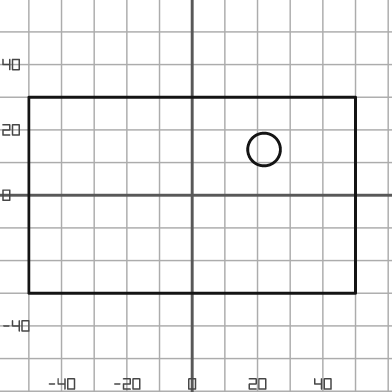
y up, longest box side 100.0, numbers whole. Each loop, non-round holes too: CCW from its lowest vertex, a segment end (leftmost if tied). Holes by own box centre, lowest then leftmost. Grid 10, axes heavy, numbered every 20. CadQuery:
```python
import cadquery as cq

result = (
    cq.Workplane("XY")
    .moveTo(-50.0, -30.0)
    .lineTo(50.0, -30.0)
    .lineTo(50.0, 30.0)
    .lineTo(-50.0, 30.0)
    .close()
    .moveTo(22.0, 14.0)
    .circle(5.0)
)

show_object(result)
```